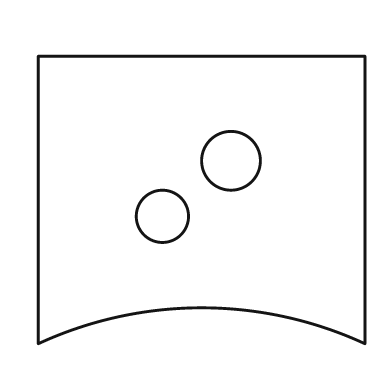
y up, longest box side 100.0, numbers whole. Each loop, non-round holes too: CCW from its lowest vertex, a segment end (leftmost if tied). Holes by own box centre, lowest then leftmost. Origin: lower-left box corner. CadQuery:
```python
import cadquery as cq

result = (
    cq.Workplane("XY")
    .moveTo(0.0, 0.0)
    .threePointArc((50.0, 11.0), (100.0, 0.0))
    .lineTo(100.0, 88.0)
    .lineTo(0.0, 88.0)
    .close()
    .moveTo(38.0, 39.0)
    .circle(8.0)
    .moveTo(59.0, 56.0)
    .circle(9.0)
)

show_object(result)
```